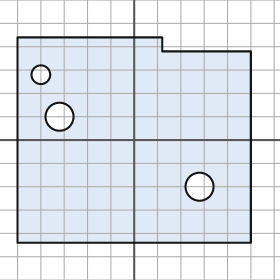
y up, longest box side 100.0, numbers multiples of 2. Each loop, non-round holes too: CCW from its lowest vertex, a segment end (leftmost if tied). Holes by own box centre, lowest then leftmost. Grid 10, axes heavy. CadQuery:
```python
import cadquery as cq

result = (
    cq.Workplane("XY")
    .moveTo(-50.0, -44.0)
    .lineTo(50.0, -44.0)
    .lineTo(50.0, 38.0)
    .lineTo(12.0, 38.0)
    .lineTo(12.0, 44.0)
    .lineTo(-50.0, 44.0)
    .close()
    .moveTo(28.0, -20.0)
    .circle(6.0)
    .moveTo(-32.0, 10.0)
    .circle(6.0)
    .moveTo(-40.0, 28.0)
    .circle(4.0)
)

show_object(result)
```